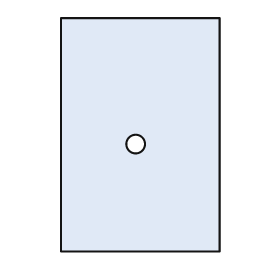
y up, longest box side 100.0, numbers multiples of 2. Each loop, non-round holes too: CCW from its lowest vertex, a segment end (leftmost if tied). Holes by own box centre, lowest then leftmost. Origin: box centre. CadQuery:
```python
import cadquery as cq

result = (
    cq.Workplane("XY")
    .moveTo(-34.0, -50.0)
    .lineTo(34.0, -50.0)
    .lineTo(34.0, 50.0)
    .lineTo(-34.0, 50.0)
    .close()
    .moveTo(-2.0, -4.0)
    .circle(4.0)
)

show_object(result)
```